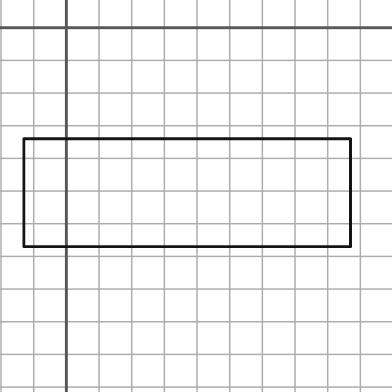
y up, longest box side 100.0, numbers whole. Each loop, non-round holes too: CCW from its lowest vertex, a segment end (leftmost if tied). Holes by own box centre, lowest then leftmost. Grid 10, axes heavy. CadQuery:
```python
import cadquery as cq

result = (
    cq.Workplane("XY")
    .moveTo(-13.0, -67.0)
    .lineTo(87.0, -67.0)
    .lineTo(87.0, -34.0)
    .lineTo(-13.0, -34.0)
    .close()
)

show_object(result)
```